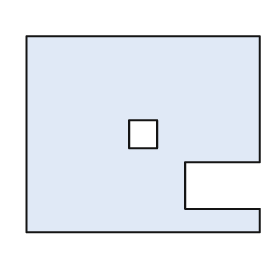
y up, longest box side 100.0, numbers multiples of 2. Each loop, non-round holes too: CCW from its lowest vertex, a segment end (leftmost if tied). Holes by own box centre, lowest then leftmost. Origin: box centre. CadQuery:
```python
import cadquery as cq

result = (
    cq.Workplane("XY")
    .moveTo(-50.0, -42.0)
    .lineTo(50.0, -42.0)
    .lineTo(50.0, -32.0)
    .lineTo(18.0, -32.0)
    .lineTo(18.0, -12.0)
    .lineTo(50.0, -12.0)
    .lineTo(50.0, 42.0)
    .lineTo(-50.0, 42.0)
    .close()
    .moveTo(-6.0, -6.0)
    .lineTo(6.0, -6.0)
    .lineTo(6.0, 6.0)
    .lineTo(-6.0, 6.0)
    .close()
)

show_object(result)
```